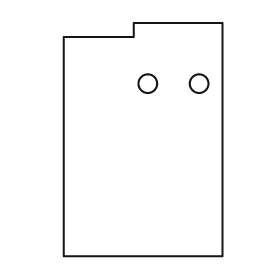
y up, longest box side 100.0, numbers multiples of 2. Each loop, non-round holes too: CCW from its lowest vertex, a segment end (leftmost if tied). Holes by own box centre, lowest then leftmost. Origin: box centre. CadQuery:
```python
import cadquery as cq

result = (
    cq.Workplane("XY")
    .moveTo(-34.0, -50.0)
    .lineTo(34.0, -50.0)
    .lineTo(34.0, 50.0)
    .lineTo(-4.0, 50.0)
    .lineTo(-4.0, 44.0)
    .lineTo(-34.0, 44.0)
    .close()
    .moveTo(2.0, 24.0)
    .circle(4.0)
    .moveTo(24.0, 24.0)
    .circle(4.0)
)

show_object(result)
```